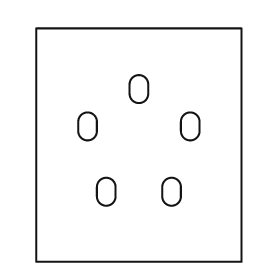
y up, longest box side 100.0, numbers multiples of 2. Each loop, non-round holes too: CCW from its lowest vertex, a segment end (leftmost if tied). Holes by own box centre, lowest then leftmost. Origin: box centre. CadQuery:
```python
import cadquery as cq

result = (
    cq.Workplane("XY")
    .moveTo(-44.0, -50.0)
    .lineTo(44.0, -50.0)
    .lineTo(44.0, 50.0)
    .lineTo(-44.0, 50.0)
    .close()
    .moveTo(-18.0, -22.0)
    .threePointArc((-14.0, -26.0), (-10.0, -22.0))
    .lineTo(-10.0, -18.0)
    .threePointArc((-14.0, -14.0), (-18.0, -18.0))
    .close()
    .moveTo(10.0, -22.0)
    .threePointArc((14.0, -26.0), (18.0, -22.0))
    .lineTo(18.0, -18.0)
    .threePointArc((14.0, -14.0), (10.0, -18.0))
    .close()
    .moveTo(-26.0, 6.0)
    .threePointArc((-22.0, 2.0), (-18.0, 6.0))
    .lineTo(-18.0, 10.0)
    .threePointArc((-22.0, 14.0), (-26.0, 10.0))
    .close()
    .moveTo(18.0, 6.0)
    .threePointArc((22.0, 2.0), (26.0, 6.0))
    .lineTo(26.0, 10.0)
    .threePointArc((22.0, 14.0), (18.0, 10.0))
    .close()
    .moveTo(-4.0, 22.0)
    .threePointArc((0.0, 18.0), (4.0, 22.0))
    .lineTo(4.0, 26.0)
    .threePointArc((0.0, 30.0), (-4.0, 26.0))
    .close()
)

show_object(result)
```